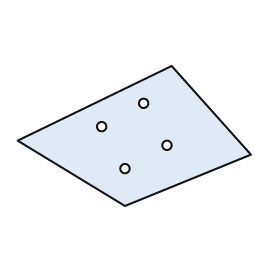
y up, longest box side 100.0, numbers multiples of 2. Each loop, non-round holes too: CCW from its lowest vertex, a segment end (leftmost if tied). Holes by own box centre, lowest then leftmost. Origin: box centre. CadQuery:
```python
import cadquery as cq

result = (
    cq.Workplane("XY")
    .moveTo(-4.0, -30.0)
    .lineTo(50.0, -8.0)
    .lineTo(16.0, 30.0)
    .lineTo(-50.0, -2.0)
    .close()
    .moveTo(-4.0, -14.0)
    .circle(2.0)
    .moveTo(14.0, -4.0)
    .circle(2.0)
    .moveTo(-14.0, 4.0)
    .circle(2.0)
    .moveTo(4.0, 14.0)
    .circle(2.0)
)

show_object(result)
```